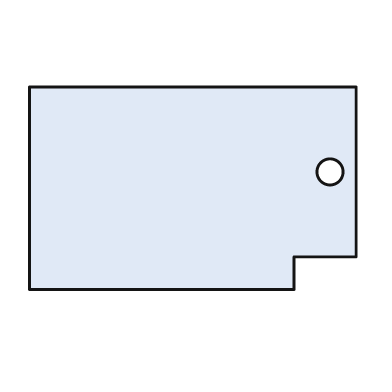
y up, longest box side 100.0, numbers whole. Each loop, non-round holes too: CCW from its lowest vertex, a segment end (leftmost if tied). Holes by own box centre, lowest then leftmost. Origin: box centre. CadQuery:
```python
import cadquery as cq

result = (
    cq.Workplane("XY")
    .moveTo(-50.0, -31.0)
    .lineTo(31.0, -31.0)
    .lineTo(31.0, -21.0)
    .lineTo(50.0, -21.0)
    .lineTo(50.0, 31.0)
    .lineTo(-50.0, 31.0)
    .close()
    .moveTo(42.0, 5.0)
    .circle(4.0)
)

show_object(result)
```